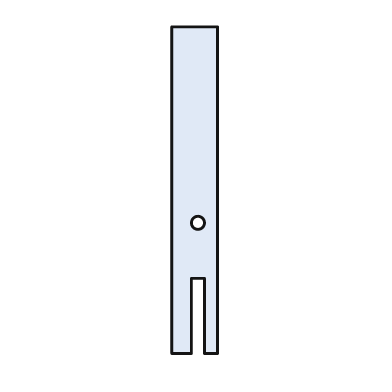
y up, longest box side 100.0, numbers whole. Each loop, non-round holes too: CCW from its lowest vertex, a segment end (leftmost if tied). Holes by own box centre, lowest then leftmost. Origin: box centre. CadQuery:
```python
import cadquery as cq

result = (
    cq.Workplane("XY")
    .moveTo(-7.0, -50.0)
    .lineTo(-1.0, -50.0)
    .lineTo(-1.0, -27.0)
    .lineTo(3.0, -27.0)
    .lineTo(3.0, -50.0)
    .lineTo(7.0, -50.0)
    .lineTo(7.0, 50.0)
    .lineTo(-7.0, 50.0)
    .close()
    .moveTo(1.0, -10.0)
    .circle(2.0)
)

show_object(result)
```